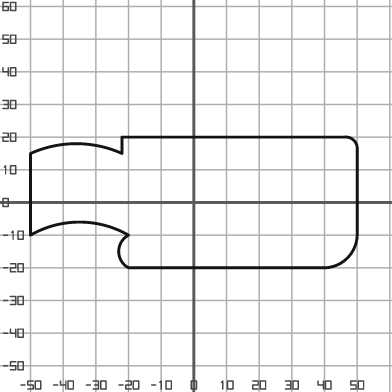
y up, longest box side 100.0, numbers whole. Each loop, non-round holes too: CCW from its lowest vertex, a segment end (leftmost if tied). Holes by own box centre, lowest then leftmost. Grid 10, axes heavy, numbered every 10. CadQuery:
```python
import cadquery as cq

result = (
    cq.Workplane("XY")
    .moveTo(-20.0, -20.0)
    .lineTo(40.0, -20.0)
    .threePointArc((47.0, -17.0), (50.0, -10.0))
    .lineTo(50.0, 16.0)
    .threePointArc((49.0, 19.0), (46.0, 20.0))
    .lineTo(-22.0, 20.0)
    .lineTo(-22.0, 15.0)
    .threePointArc((-36.0, 18.0), (-50.0, 15.0))
    .lineTo(-50.0, -10.0)
    .threePointArc((-35.0, -6.0), (-20.0, -10.0))
    .threePointArc((-23.0, -15.0), (-20.0, -20.0))
    .close()
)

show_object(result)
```